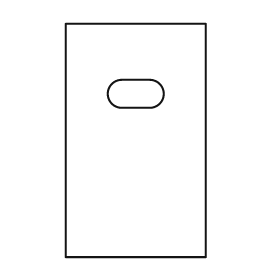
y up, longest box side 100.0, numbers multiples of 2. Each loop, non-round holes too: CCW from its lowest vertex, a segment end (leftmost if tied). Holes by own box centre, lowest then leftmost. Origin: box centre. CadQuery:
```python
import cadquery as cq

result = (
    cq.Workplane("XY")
    .moveTo(-30.0, -50.0)
    .lineTo(30.0, -50.0)
    .lineTo(30.0, 50.0)
    .lineTo(-30.0, 50.0)
    .close()
    .moveTo(-6.0, 14.0)
    .lineTo(6.0, 14.0)
    .threePointArc((12.0, 20.0), (6.0, 26.0))
    .lineTo(-6.0, 26.0)
    .threePointArc((-12.0, 20.0), (-6.0, 14.0))
    .close()
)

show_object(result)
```